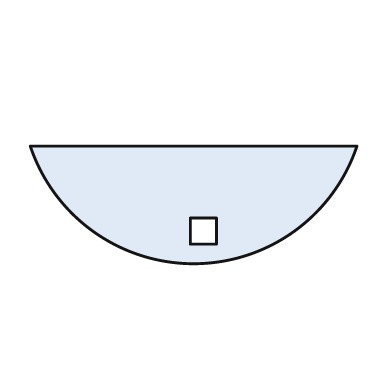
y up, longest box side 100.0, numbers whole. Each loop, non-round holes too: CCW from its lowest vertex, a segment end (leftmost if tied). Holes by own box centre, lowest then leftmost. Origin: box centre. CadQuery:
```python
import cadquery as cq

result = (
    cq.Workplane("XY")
    .moveTo(-50.0, 18.0)
    .threePointArc((0.0, -18.0), (50.0, 18.0))
    .close()
    .moveTo(-1.0, -12.0)
    .lineTo(7.0, -12.0)
    .lineTo(7.0, -4.0)
    .lineTo(-1.0, -4.0)
    .close()
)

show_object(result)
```